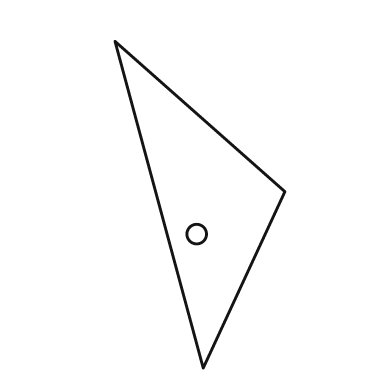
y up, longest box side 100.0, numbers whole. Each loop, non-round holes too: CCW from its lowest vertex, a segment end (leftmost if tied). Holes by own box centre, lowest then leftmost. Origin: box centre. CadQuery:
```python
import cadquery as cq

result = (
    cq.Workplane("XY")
    .moveTo(1.0, -50.0)
    .lineTo(26.0, 4.0)
    .lineTo(-26.0, 50.0)
    .close()
    .moveTo(-1.0, -9.0)
    .circle(3.0)
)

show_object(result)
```